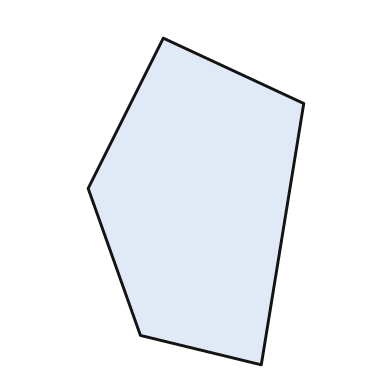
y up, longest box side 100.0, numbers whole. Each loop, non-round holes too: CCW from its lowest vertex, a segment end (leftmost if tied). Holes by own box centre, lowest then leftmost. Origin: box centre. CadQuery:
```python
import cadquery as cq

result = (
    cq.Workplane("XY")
    .moveTo(20.0, -50.0)
    .lineTo(33.0, 30.0)
    .lineTo(-10.0, 50.0)
    .lineTo(-33.0, 4.0)
    .lineTo(-17.0, -41.0)
    .close()
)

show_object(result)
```